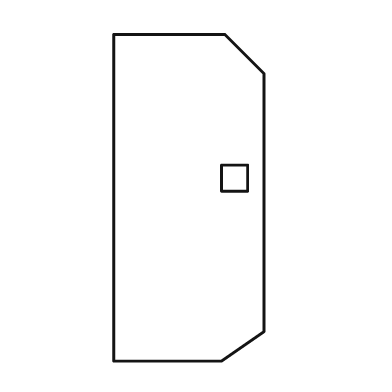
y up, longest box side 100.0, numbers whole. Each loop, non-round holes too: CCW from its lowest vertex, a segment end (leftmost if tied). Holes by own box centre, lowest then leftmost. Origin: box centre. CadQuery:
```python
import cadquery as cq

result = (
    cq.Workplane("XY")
    .moveTo(-23.0, -50.0)
    .lineTo(10.0, -50.0)
    .lineTo(23.0, -41.0)
    .lineTo(23.0, 38.0)
    .lineTo(11.0, 50.0)
    .lineTo(-23.0, 50.0)
    .close()
    .moveTo(10.0, 2.0)
    .lineTo(18.0, 2.0)
    .lineTo(18.0, 10.0)
    .lineTo(10.0, 10.0)
    .close()
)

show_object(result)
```